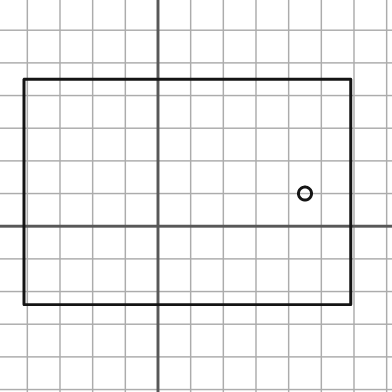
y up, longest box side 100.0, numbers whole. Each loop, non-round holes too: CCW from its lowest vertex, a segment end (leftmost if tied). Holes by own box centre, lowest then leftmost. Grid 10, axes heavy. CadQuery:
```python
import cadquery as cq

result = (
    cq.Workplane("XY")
    .moveTo(-41.0, -24.0)
    .lineTo(59.0, -24.0)
    .lineTo(59.0, 45.0)
    .lineTo(-41.0, 45.0)
    .close()
    .moveTo(45.0, 10.0)
    .circle(2.0)
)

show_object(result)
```